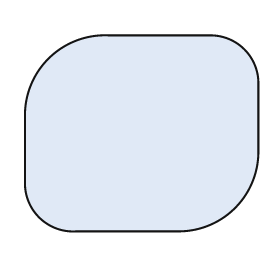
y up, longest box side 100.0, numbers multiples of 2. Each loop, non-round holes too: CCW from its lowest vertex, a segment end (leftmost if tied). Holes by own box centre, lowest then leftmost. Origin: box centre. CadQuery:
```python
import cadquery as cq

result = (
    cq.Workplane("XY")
    .moveTo(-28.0, -42.0)
    .lineTo(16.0, -42.0)
    .threePointArc((40.0, -32.0), (50.0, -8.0))
    .lineTo(50.0, 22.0)
    .threePointArc((44.0, 36.0), (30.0, 42.0))
    .lineTo(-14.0, 42.0)
    .threePointArc((-40.0, 32.0), (-50.0, 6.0))
    .lineTo(-50.0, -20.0)
    .threePointArc((-44.0, -36.0), (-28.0, -42.0))
    .close()
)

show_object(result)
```